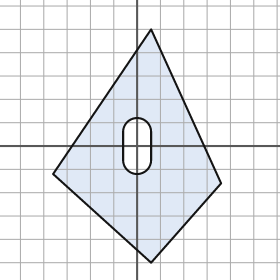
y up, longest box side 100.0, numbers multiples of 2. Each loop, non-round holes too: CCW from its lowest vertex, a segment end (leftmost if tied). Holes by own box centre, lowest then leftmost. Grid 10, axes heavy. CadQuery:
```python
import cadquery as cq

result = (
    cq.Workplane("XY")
    .moveTo(6.0, -50.0)
    .lineTo(36.0, -16.0)
    .lineTo(6.0, 50.0)
    .lineTo(-36.0, -12.0)
    .close()
    .moveTo(-6.0, -6.0)
    .threePointArc((0.0, -12.0), (6.0, -6.0))
    .lineTo(6.0, 6.0)
    .threePointArc((0.0, 12.0), (-6.0, 6.0))
    .close()
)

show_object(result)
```